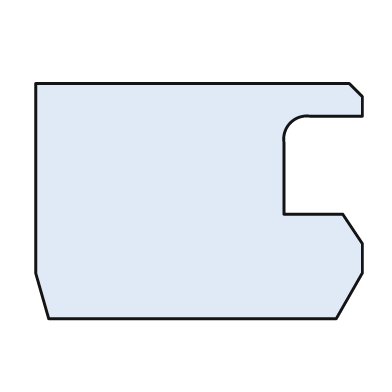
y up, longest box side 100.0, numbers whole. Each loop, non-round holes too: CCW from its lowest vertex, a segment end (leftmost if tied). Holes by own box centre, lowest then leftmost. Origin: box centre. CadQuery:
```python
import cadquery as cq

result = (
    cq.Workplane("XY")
    .moveTo(-46.0, -36.0)
    .lineTo(42.0, -36.0)
    .lineTo(50.0, -22.0)
    .lineTo(50.0, -13.0)
    .lineTo(44.0, -4.0)
    .lineTo(26.0, -4.0)
    .lineTo(26.0, 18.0)
    .threePointArc((28.0, 24.0), (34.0, 26.0))
    .lineTo(50.0, 26.0)
    .lineTo(50.0, 32.0)
    .lineTo(46.0, 36.0)
    .lineTo(-50.0, 36.0)
    .lineTo(-50.0, -22.0)
    .close()
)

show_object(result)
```